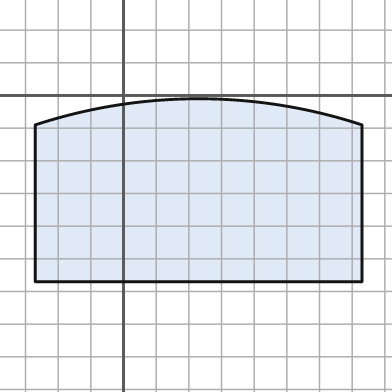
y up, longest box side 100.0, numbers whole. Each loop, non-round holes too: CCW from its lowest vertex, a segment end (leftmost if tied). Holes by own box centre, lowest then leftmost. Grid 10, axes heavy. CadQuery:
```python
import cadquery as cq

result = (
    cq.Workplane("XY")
    .moveTo(-27.0, -57.0)
    .lineTo(73.0, -57.0)
    .lineTo(73.0, -9.0)
    .threePointArc((23.0, -1.0), (-27.0, -9.0))
    .close()
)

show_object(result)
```